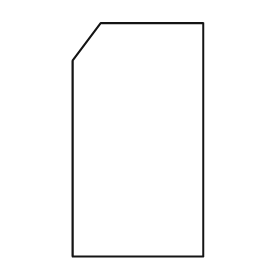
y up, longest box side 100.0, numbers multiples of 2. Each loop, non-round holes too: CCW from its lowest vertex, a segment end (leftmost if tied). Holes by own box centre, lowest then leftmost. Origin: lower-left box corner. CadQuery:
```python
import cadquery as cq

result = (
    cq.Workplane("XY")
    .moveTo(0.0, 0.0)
    .lineTo(56.0, 0.0)
    .lineTo(56.0, 100.0)
    .lineTo(12.0, 100.0)
    .lineTo(0.0, 84.0)
    .close()
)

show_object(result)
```